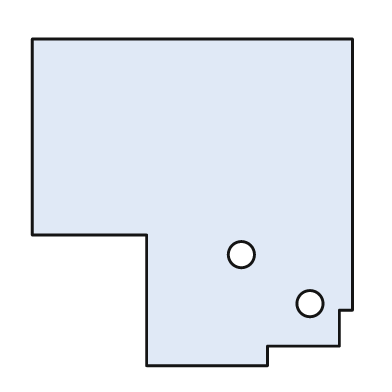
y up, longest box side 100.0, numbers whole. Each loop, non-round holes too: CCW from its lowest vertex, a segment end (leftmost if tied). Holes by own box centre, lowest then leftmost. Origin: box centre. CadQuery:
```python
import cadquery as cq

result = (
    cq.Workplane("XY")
    .moveTo(-14.0, -50.0)
    .lineTo(23.0, -50.0)
    .lineTo(23.0, -44.0)
    .lineTo(45.0, -44.0)
    .lineTo(45.0, -33.0)
    .lineTo(49.0, -33.0)
    .lineTo(49.0, 50.0)
    .lineTo(-49.0, 50.0)
    .lineTo(-49.0, -10.0)
    .lineTo(-14.0, -10.0)
    .close()
    .moveTo(36.0, -31.0)
    .circle(4.0)
    .moveTo(15.0, -16.0)
    .circle(4.0)
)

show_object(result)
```